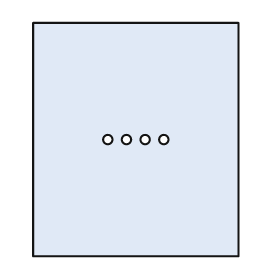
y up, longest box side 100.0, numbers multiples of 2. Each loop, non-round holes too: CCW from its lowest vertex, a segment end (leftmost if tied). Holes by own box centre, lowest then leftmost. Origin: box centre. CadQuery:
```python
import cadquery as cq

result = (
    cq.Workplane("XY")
    .moveTo(-44.0, -50.0)
    .lineTo(44.0, -50.0)
    .lineTo(44.0, 50.0)
    .lineTo(-44.0, 50.0)
    .close()
    .moveTo(-12.0, 0.0)
    .circle(2.0)
    .moveTo(-4.0, 0.0)
    .circle(2.0)
    .moveTo(4.0, 0.0)
    .circle(2.0)
    .moveTo(12.0, 0.0)
    .circle(2.0)
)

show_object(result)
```